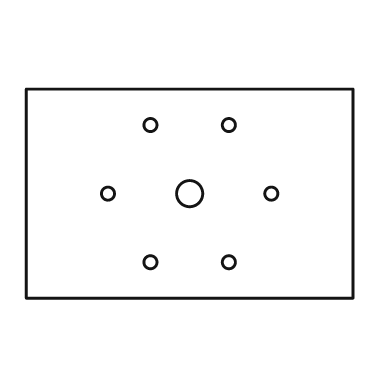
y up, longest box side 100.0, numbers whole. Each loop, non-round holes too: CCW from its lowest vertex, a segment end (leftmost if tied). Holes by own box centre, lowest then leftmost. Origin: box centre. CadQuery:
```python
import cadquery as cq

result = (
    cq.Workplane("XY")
    .moveTo(-50.0, -32.0)
    .lineTo(50.0, -32.0)
    .lineTo(50.0, 32.0)
    .lineTo(-50.0, 32.0)
    .close()
    .moveTo(-12.0, -21.0)
    .circle(2.0)
    .moveTo(12.0, -21.0)
    .circle(2.0)
    .moveTo(-25.0, 0.0)
    .circle(2.0)
    .moveTo(0.0, 0.0)
    .circle(4.0)
    .moveTo(25.0, 0.0)
    .circle(2.0)
    .moveTo(-12.0, 21.0)
    .circle(2.0)
    .moveTo(12.0, 21.0)
    .circle(2.0)
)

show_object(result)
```